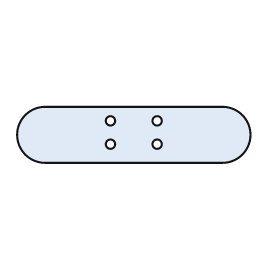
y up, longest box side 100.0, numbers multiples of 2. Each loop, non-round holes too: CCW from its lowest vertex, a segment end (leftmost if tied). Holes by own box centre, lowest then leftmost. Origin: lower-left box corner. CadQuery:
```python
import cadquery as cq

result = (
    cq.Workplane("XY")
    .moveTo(12.0, 0.0)
    .lineTo(88.0, 0.0)
    .threePointArc((100.0, 12.0), (88.0, 24.0))
    .lineTo(12.0, 24.0)
    .threePointArc((0.0, 12.0), (12.0, 0.0))
    .close()
    .moveTo(40.0, 8.0)
    .circle(2.0)
    .moveTo(60.0, 8.0)
    .circle(2.0)
    .moveTo(40.0, 18.0)
    .circle(2.0)
    .moveTo(60.0, 18.0)
    .circle(2.0)
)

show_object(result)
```